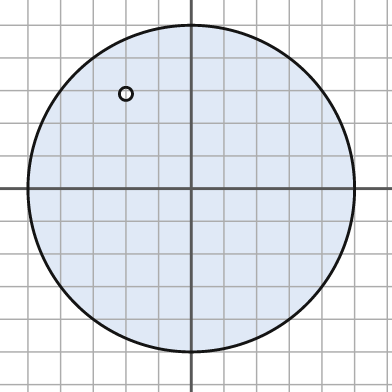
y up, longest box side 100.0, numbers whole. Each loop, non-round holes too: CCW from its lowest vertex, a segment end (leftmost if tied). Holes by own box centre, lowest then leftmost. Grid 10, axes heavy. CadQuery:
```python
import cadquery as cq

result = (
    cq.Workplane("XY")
    .moveTo(0.0, 0.0)
    .circle(50.0)
    .moveTo(-20.0, 29.0)
    .circle(2.0)
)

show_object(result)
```